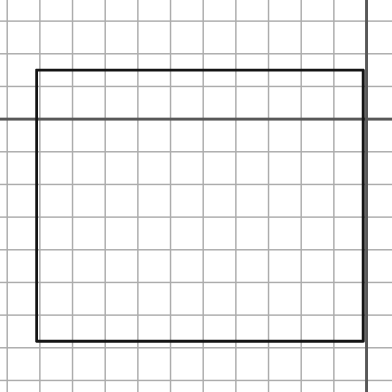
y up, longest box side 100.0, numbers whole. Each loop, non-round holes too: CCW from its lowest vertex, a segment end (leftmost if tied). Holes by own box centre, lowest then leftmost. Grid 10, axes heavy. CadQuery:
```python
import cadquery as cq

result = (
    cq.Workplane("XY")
    .moveTo(-101.0, -68.0)
    .lineTo(-1.0, -68.0)
    .lineTo(-1.0, 15.0)
    .lineTo(-101.0, 15.0)
    .close()
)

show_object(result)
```